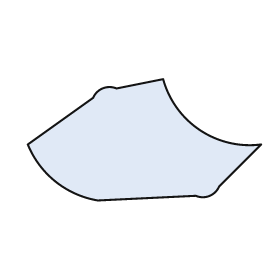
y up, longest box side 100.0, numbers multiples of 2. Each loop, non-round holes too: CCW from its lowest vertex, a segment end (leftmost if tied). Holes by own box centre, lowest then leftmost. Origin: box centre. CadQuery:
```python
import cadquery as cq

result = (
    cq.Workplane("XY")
    .moveTo(-20.0, -26.0)
    .lineTo(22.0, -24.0)
    .threePointArc((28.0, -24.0), (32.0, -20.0))
    .lineTo(50.0, -2.0)
    .threePointArc((24.0, 4.0), (8.0, 26.0))
    .lineTo(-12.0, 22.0)
    .threePointArc((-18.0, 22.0), (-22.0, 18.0))
    .lineTo(-50.0, -2.0)
    .threePointArc((-38.0, -18.0), (-20.0, -26.0))
    .close()
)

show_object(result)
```